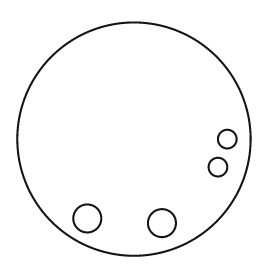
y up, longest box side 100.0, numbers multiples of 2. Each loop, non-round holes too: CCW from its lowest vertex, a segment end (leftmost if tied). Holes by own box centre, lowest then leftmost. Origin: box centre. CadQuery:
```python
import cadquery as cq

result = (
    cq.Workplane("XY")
    .moveTo(0.0, 0.0)
    .circle(50.0)
    .moveTo(12.0, -36.0)
    .circle(6.0)
    .moveTo(-20.0, -34.0)
    .circle(6.0)
    .moveTo(36.0, -12.0)
    .circle(4.0)
    .moveTo(40.0, 0.0)
    .circle(4.0)
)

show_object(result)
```